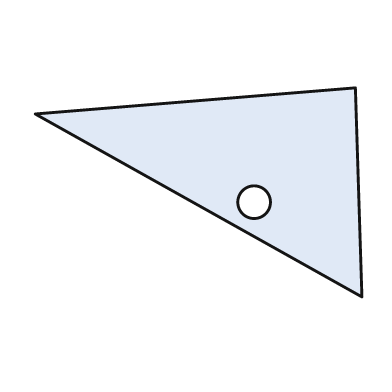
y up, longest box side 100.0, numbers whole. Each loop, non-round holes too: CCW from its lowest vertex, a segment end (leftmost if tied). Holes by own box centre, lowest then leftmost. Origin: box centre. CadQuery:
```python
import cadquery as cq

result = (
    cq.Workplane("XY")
    .moveTo(50.0, -32.0)
    .lineTo(48.0, 32.0)
    .lineTo(-50.0, 24.0)
    .close()
    .moveTo(17.0, -3.0)
    .circle(5.0)
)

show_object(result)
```